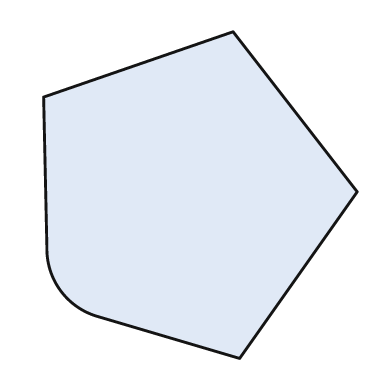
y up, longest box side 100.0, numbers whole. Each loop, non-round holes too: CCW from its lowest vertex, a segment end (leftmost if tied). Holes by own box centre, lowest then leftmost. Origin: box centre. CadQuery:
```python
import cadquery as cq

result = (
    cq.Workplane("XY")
    .moveTo(12.0, -50.0)
    .lineTo(48.0, 1.0)
    .lineTo(10.0, 50.0)
    .lineTo(-48.0, 30.0)
    .lineTo(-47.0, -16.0)
    .threePointArc((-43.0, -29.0), (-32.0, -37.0))
    .close()
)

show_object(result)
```